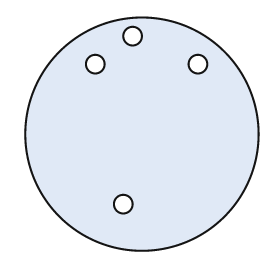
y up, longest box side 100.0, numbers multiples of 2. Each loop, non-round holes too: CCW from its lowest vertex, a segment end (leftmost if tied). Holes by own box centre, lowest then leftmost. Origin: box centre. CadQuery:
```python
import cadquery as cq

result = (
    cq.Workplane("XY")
    .moveTo(0.0, 0.0)
    .circle(50.0)
    .moveTo(-8.0, -30.0)
    .circle(4.0)
    .moveTo(-20.0, 30.0)
    .circle(4.0)
    .moveTo(24.0, 30.0)
    .circle(4.0)
    .moveTo(-4.0, 42.0)
    .circle(4.0)
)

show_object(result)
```